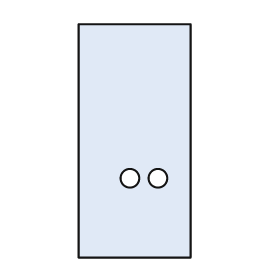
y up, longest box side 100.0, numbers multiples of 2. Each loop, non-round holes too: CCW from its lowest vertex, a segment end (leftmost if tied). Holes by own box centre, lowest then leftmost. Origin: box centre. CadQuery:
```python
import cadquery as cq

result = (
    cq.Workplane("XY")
    .moveTo(-24.0, -50.0)
    .lineTo(24.0, -50.0)
    .lineTo(24.0, 50.0)
    .lineTo(-24.0, 50.0)
    .close()
    .moveTo(-2.0, -16.0)
    .circle(4.0)
    .moveTo(10.0, -16.0)
    .circle(4.0)
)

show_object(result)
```